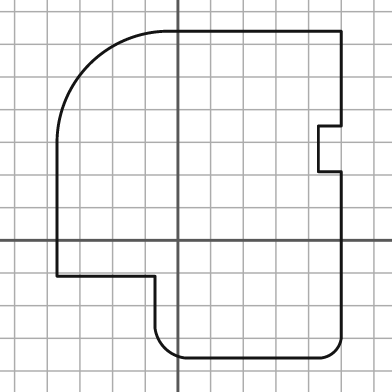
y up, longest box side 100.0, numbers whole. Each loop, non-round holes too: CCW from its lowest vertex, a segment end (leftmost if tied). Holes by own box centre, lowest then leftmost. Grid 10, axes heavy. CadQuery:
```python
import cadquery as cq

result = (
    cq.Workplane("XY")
    .moveTo(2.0, -36.0)
    .lineTo(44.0, -36.0)
    .threePointArc((48.0, -34.0), (50.0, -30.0))
    .lineTo(50.0, 21.0)
    .lineTo(43.0, 21.0)
    .lineTo(43.0, 35.0)
    .lineTo(50.0, 35.0)
    .lineTo(50.0, 64.0)
    .lineTo(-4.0, 64.0)
    .threePointArc((-27.0, 54.0), (-37.0, 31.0))
    .lineTo(-37.0, -11.0)
    .lineTo(-7.0, -11.0)
    .lineTo(-7.0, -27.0)
    .threePointArc((-4.0, -33.0), (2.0, -36.0))
    .close()
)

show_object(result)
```